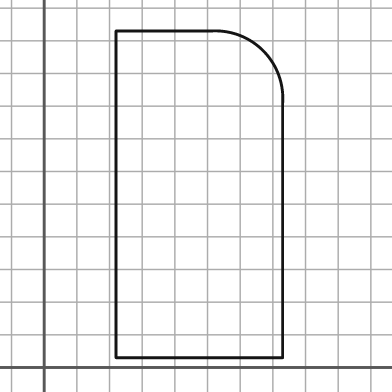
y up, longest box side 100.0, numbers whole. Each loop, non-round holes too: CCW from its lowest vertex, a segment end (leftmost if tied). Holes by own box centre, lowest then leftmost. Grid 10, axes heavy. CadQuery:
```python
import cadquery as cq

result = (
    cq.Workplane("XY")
    .moveTo(22.0, 3.0)
    .lineTo(73.0, 3.0)
    .lineTo(73.0, 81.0)
    .threePointArc((67.0, 97.0), (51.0, 103.0))
    .lineTo(22.0, 103.0)
    .close()
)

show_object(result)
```